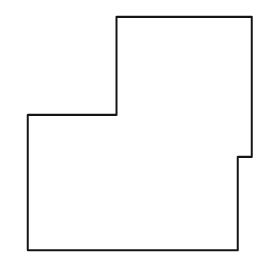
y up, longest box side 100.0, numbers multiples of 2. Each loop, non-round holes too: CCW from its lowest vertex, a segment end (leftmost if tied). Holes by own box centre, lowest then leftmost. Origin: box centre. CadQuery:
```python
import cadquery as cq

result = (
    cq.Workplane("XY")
    .moveTo(-48.0, -50.0)
    .lineTo(42.0, -50.0)
    .lineTo(42.0, -10.0)
    .lineTo(48.0, -10.0)
    .lineTo(48.0, 50.0)
    .lineTo(-10.0, 50.0)
    .lineTo(-10.0, 8.0)
    .lineTo(-48.0, 8.0)
    .close()
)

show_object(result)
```